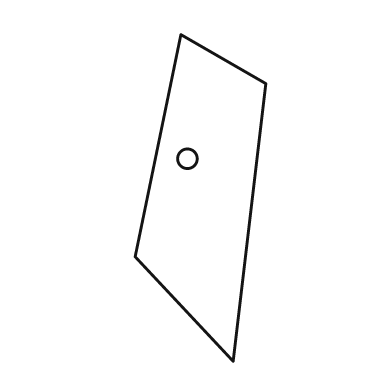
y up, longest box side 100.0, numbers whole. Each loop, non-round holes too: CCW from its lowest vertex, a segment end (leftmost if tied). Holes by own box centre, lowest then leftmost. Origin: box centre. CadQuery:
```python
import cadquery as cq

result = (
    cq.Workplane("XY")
    .moveTo(10.0, -50.0)
    .lineTo(20.0, 35.0)
    .lineTo(-6.0, 50.0)
    .lineTo(-20.0, -18.0)
    .close()
    .moveTo(-4.0, 12.0)
    .circle(3.0)
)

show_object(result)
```